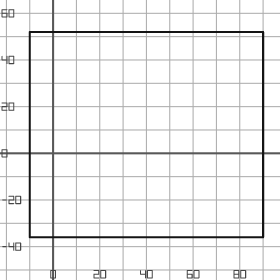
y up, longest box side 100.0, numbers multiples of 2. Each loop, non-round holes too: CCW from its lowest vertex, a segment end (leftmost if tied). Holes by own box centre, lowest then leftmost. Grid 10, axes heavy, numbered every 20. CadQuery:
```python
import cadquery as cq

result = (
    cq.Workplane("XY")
    .moveTo(-10.0, -36.0)
    .lineTo(90.0, -36.0)
    .lineTo(90.0, 52.0)
    .lineTo(-10.0, 52.0)
    .close()
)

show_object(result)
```